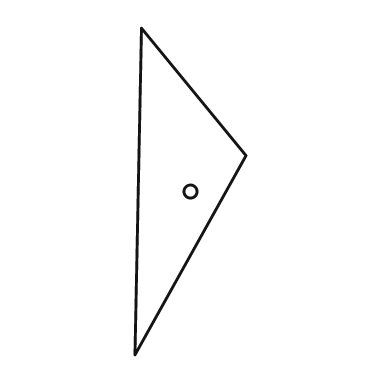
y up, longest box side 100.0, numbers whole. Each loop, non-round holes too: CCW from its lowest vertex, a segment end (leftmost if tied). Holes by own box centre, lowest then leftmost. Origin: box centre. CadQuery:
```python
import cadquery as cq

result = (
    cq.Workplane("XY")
    .moveTo(-17.0, -50.0)
    .lineTo(17.0, 11.0)
    .lineTo(-15.0, 50.0)
    .close()
    .moveTo(0.0, 0.0)
    .circle(2.0)
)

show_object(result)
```